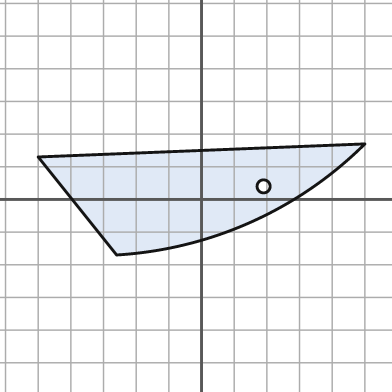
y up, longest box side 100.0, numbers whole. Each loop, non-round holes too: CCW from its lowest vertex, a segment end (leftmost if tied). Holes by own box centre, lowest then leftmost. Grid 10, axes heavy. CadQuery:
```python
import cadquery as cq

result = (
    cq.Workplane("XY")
    .moveTo(-26.0, -17.0)
    .threePointArc((15.0, -7.0), (50.0, 17.0))
    .lineTo(-50.0, 13.0)
    .close()
    .moveTo(19.0, 4.0)
    .circle(2.0)
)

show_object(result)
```